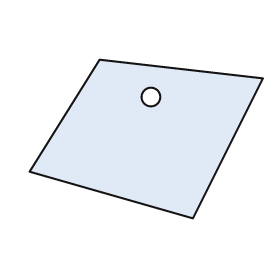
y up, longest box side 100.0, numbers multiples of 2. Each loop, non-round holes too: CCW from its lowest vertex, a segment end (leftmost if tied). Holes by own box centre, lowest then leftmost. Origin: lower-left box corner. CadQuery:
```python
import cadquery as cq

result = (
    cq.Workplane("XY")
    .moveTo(70.0, 0.0)
    .lineTo(100.0, 60.0)
    .lineTo(30.0, 68.0)
    .lineTo(0.0, 20.0)
    .close()
    .moveTo(52.0, 52.0)
    .circle(4.0)
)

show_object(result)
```